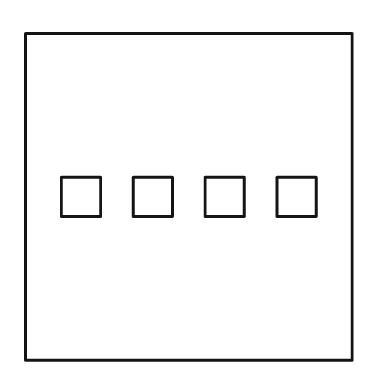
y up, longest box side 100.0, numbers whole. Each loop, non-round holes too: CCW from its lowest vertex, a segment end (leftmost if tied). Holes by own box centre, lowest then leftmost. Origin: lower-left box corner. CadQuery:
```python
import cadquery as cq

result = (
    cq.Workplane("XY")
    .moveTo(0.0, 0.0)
    .lineTo(100.0, 0.0)
    .lineTo(100.0, 100.0)
    .lineTo(0.0, 100.0)
    .close()
    .moveTo(11.0, 44.0)
    .lineTo(23.0, 44.0)
    .lineTo(23.0, 56.0)
    .lineTo(11.0, 56.0)
    .close()
    .moveTo(33.0, 44.0)
    .lineTo(45.0, 44.0)
    .lineTo(45.0, 56.0)
    .lineTo(33.0, 56.0)
    .close()
    .moveTo(55.0, 44.0)
    .lineTo(67.0, 44.0)
    .lineTo(67.0, 56.0)
    .lineTo(55.0, 56.0)
    .close()
    .moveTo(77.0, 44.0)
    .lineTo(89.0, 44.0)
    .lineTo(89.0, 56.0)
    .lineTo(77.0, 56.0)
    .close()
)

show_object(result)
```